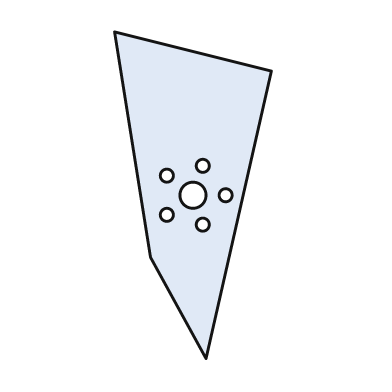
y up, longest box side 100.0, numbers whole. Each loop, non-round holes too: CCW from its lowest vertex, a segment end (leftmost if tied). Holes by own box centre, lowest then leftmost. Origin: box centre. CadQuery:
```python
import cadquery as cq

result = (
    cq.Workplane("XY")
    .moveTo(4.0, -50.0)
    .lineTo(24.0, 38.0)
    .lineTo(-24.0, 50.0)
    .lineTo(-13.0, -19.0)
    .close()
    .moveTo(3.0, -9.0)
    .circle(2.0)
    .moveTo(-8.0, -6.0)
    .circle(2.0)
    .moveTo(0.0, 0.0)
    .circle(4.0)
    .moveTo(10.0, 0.0)
    .circle(2.0)
    .moveTo(-8.0, 6.0)
    .circle(2.0)
    .moveTo(3.0, 9.0)
    .circle(2.0)
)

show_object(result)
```